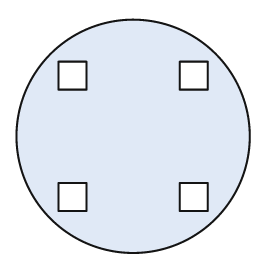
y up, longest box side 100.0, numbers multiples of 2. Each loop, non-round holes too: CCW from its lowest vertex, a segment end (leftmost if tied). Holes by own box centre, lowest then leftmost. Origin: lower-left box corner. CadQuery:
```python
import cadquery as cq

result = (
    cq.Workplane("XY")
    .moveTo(50.0, 50.0)
    .circle(50.0)
    .moveTo(18.0, 18.0)
    .lineTo(30.0, 18.0)
    .lineTo(30.0, 30.0)
    .lineTo(18.0, 30.0)
    .close()
    .moveTo(70.0, 18.0)
    .lineTo(82.0, 18.0)
    .lineTo(82.0, 30.0)
    .lineTo(70.0, 30.0)
    .close()
    .moveTo(18.0, 70.0)
    .lineTo(30.0, 70.0)
    .lineTo(30.0, 82.0)
    .lineTo(18.0, 82.0)
    .close()
    .moveTo(70.0, 70.0)
    .lineTo(82.0, 70.0)
    .lineTo(82.0, 82.0)
    .lineTo(70.0, 82.0)
    .close()
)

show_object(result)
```